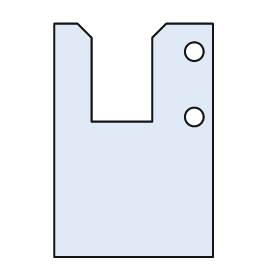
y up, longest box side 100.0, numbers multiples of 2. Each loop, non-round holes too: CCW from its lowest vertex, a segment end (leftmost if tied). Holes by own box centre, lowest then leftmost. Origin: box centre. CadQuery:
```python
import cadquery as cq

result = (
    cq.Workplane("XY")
    .moveTo(-34.0, -50.0)
    .lineTo(34.0, -50.0)
    .lineTo(34.0, 50.0)
    .lineTo(14.0, 50.0)
    .lineTo(8.0, 44.0)
    .lineTo(8.0, 8.0)
    .lineTo(-18.0, 8.0)
    .lineTo(-18.0, 44.0)
    .lineTo(-24.0, 50.0)
    .lineTo(-34.0, 50.0)
    .close()
    .moveTo(26.0, 10.0)
    .circle(4.0)
    .moveTo(26.0, 38.0)
    .circle(4.0)
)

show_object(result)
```